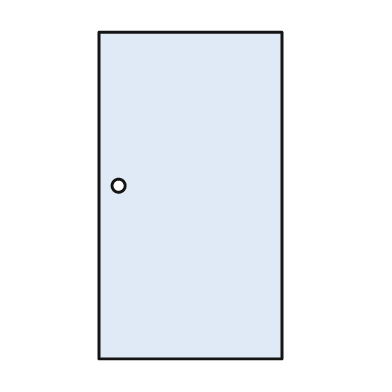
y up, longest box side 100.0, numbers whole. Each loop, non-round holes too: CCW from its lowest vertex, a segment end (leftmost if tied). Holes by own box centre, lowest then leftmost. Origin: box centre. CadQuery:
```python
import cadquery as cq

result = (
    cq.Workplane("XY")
    .moveTo(-28.0, -50.0)
    .lineTo(28.0, -50.0)
    .lineTo(28.0, 50.0)
    .lineTo(-28.0, 50.0)
    .close()
    .moveTo(-22.0, 3.0)
    .circle(2.0)
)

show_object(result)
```